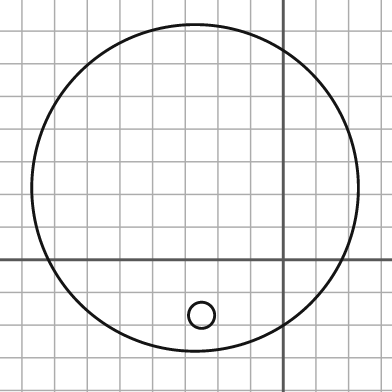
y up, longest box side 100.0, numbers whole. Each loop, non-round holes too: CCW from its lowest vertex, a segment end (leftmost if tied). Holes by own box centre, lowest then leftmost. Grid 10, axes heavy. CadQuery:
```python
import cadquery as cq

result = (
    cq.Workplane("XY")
    .moveTo(-27.0, 22.0)
    .circle(50.0)
    .moveTo(-25.0, -17.0)
    .circle(4.0)
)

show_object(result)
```